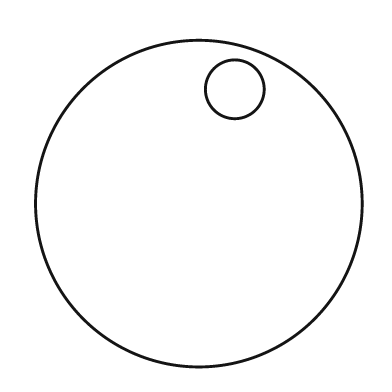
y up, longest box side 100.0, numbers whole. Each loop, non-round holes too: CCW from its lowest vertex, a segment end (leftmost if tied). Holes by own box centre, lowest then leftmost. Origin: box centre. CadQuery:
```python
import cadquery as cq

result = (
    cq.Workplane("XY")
    .moveTo(0.0, 0.0)
    .circle(50.0)
    .moveTo(11.0, 35.0)
    .circle(9.0)
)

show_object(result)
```